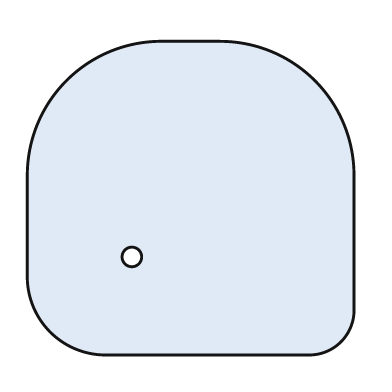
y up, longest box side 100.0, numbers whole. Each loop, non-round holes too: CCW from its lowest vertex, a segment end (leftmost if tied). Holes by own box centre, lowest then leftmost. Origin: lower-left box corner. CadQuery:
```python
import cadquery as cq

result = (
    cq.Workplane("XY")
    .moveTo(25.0, 0.0)
    .lineTo(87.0, 0.0)
    .threePointArc((96.0, 4.0), (100.0, 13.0))
    .lineTo(100.0, 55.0)
    .threePointArc((88.0, 84.0), (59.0, 96.0))
    .lineTo(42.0, 96.0)
    .threePointArc((12.0, 84.0), (0.0, 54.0))
    .lineTo(0.0, 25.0)
    .threePointArc((7.0, 7.0), (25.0, 0.0))
    .close()
    .moveTo(32.0, 30.0)
    .circle(3.0)
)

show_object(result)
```